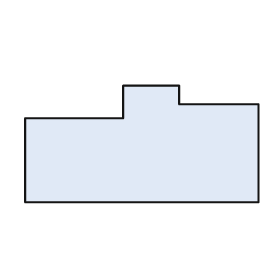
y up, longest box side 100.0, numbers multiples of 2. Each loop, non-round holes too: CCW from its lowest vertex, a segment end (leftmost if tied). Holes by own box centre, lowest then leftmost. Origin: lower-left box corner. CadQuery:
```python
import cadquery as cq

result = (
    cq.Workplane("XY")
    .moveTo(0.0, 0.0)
    .lineTo(100.0, 0.0)
    .lineTo(100.0, 42.0)
    .lineTo(66.0, 42.0)
    .lineTo(66.0, 50.0)
    .lineTo(42.0, 50.0)
    .lineTo(42.0, 36.0)
    .lineTo(0.0, 36.0)
    .close()
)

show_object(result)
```